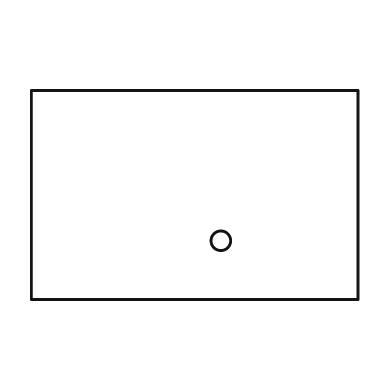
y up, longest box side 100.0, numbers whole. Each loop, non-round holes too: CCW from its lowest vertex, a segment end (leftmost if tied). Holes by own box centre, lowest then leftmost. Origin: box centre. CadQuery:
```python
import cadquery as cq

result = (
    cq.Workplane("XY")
    .moveTo(-50.0, -32.0)
    .lineTo(50.0, -32.0)
    .lineTo(50.0, 32.0)
    .lineTo(-50.0, 32.0)
    .close()
    .moveTo(8.0, -14.0)
    .circle(3.0)
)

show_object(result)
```